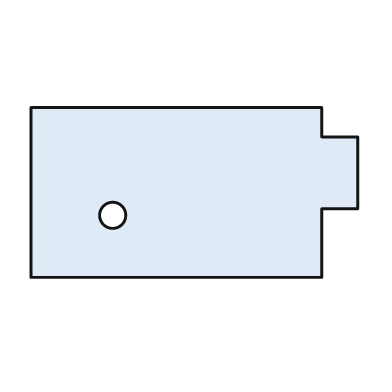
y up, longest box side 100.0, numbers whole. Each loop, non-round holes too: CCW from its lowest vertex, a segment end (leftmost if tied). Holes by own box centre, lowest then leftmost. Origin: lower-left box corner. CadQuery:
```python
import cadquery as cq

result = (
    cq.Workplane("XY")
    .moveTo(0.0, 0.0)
    .lineTo(89.0, 0.0)
    .lineTo(89.0, 21.0)
    .lineTo(100.0, 21.0)
    .lineTo(100.0, 43.0)
    .lineTo(89.0, 43.0)
    .lineTo(89.0, 52.0)
    .lineTo(0.0, 52.0)
    .close()
    .moveTo(25.0, 19.0)
    .circle(4.0)
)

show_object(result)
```